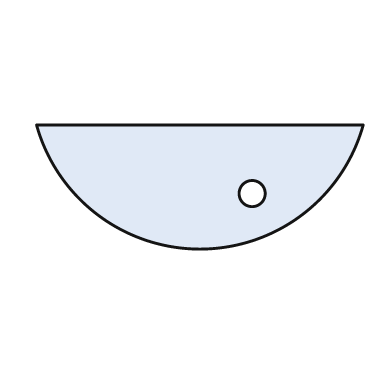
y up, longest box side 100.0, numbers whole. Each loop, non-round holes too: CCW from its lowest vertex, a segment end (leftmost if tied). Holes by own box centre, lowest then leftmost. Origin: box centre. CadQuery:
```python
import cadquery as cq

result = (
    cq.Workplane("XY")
    .moveTo(-50.0, 19.0)
    .threePointArc((0.0, -19.0), (50.0, 19.0))
    .close()
    .moveTo(16.0, -2.0)
    .circle(4.0)
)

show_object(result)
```